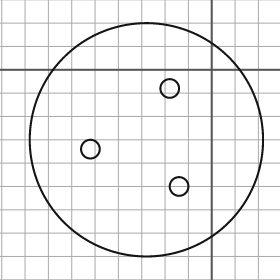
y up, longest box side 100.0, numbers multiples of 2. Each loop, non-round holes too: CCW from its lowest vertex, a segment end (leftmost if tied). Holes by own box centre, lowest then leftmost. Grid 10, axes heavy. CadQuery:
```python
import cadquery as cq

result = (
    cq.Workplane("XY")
    .moveTo(-28.0, -30.0)
    .circle(50.0)
    .moveTo(-14.0, -50.0)
    .circle(4.0)
    .moveTo(-52.0, -34.0)
    .circle(4.0)
    .moveTo(-18.0, -8.0)
    .circle(4.0)
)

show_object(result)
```